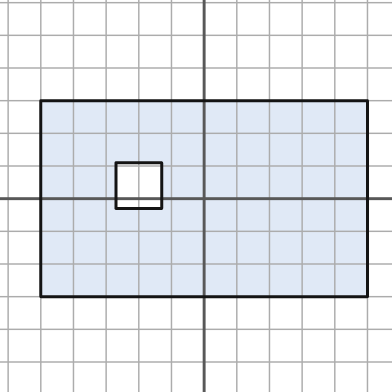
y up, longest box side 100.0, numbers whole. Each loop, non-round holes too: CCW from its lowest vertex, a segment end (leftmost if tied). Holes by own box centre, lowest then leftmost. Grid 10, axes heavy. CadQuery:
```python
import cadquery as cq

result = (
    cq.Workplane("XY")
    .moveTo(-50.0, -30.0)
    .lineTo(50.0, -30.0)
    .lineTo(50.0, 30.0)
    .lineTo(-50.0, 30.0)
    .close()
    .moveTo(-27.0, -3.0)
    .lineTo(-13.0, -3.0)
    .lineTo(-13.0, 11.0)
    .lineTo(-27.0, 11.0)
    .close()
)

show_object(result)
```